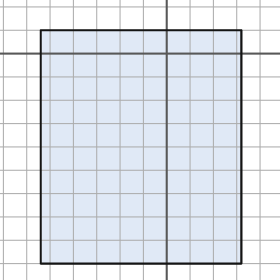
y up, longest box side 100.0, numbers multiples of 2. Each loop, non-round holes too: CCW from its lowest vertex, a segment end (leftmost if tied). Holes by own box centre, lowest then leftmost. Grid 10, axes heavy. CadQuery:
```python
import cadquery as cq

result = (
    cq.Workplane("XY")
    .moveTo(-54.0, -90.0)
    .lineTo(32.0, -90.0)
    .lineTo(32.0, 10.0)
    .lineTo(-54.0, 10.0)
    .close()
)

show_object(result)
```